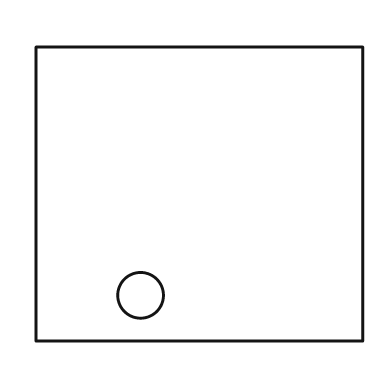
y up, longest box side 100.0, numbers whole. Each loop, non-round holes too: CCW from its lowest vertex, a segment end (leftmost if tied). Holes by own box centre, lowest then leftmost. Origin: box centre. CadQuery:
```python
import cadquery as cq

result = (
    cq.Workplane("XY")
    .moveTo(-50.0, -45.0)
    .lineTo(50.0, -45.0)
    .lineTo(50.0, 45.0)
    .lineTo(-50.0, 45.0)
    .close()
    .moveTo(-18.0, -31.0)
    .circle(7.0)
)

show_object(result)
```